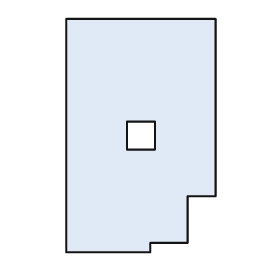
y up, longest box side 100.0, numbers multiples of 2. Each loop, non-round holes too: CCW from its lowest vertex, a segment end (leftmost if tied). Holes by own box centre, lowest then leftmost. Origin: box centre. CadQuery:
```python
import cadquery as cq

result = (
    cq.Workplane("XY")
    .moveTo(-32.0, -50.0)
    .lineTo(4.0, -50.0)
    .lineTo(4.0, -46.0)
    .lineTo(20.0, -46.0)
    .lineTo(20.0, -26.0)
    .lineTo(32.0, -26.0)
    .lineTo(32.0, 50.0)
    .lineTo(-32.0, 50.0)
    .close()
    .moveTo(-6.0, -6.0)
    .lineTo(6.0, -6.0)
    .lineTo(6.0, 6.0)
    .lineTo(-6.0, 6.0)
    .close()
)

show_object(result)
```